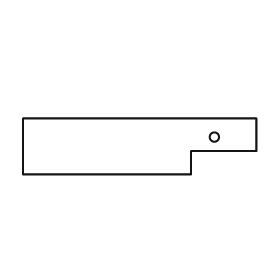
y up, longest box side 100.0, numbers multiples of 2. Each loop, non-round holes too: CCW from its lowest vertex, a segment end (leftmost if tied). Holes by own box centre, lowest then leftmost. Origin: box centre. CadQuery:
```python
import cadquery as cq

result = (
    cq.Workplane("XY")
    .moveTo(-50.0, -12.0)
    .lineTo(22.0, -12.0)
    .lineTo(22.0, -2.0)
    .lineTo(50.0, -2.0)
    .lineTo(50.0, 12.0)
    .lineTo(-50.0, 12.0)
    .close()
    .moveTo(32.0, 4.0)
    .circle(2.0)
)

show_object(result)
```